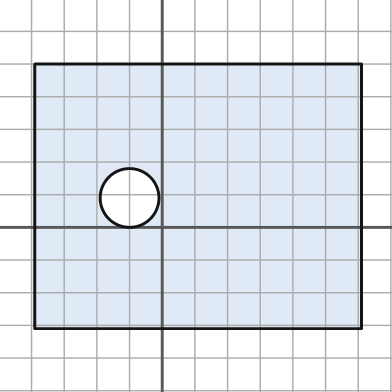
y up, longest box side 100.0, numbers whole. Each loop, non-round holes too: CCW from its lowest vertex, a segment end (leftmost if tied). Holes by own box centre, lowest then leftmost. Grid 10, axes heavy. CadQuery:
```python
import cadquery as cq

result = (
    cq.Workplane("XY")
    .moveTo(-39.0, -31.0)
    .lineTo(61.0, -31.0)
    .lineTo(61.0, 50.0)
    .lineTo(-39.0, 50.0)
    .close()
    .moveTo(-10.0, 9.0)
    .circle(9.0)
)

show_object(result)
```